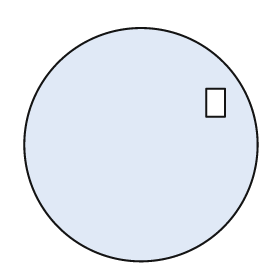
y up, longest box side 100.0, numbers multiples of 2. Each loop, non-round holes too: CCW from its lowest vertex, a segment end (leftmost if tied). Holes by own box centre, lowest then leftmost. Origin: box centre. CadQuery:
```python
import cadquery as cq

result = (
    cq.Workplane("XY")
    .moveTo(0.0, 0.0)
    .circle(50.0)
    .moveTo(28.0, 12.0)
    .lineTo(36.0, 12.0)
    .lineTo(36.0, 24.0)
    .lineTo(28.0, 24.0)
    .close()
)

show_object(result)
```